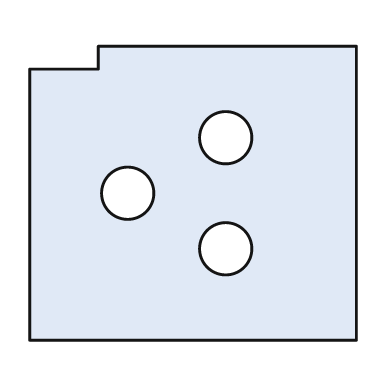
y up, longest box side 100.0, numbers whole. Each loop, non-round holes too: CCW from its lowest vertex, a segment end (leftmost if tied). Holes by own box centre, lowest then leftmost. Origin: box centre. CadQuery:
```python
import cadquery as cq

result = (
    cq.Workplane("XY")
    .moveTo(-50.0, -45.0)
    .lineTo(50.0, -45.0)
    .lineTo(50.0, 45.0)
    .lineTo(-29.0, 45.0)
    .lineTo(-29.0, 38.0)
    .lineTo(-50.0, 38.0)
    .close()
    .moveTo(10.0, -17.0)
    .circle(8.0)
    .moveTo(-20.0, 0.0)
    .circle(8.0)
    .moveTo(10.0, 17.0)
    .circle(8.0)
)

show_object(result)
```